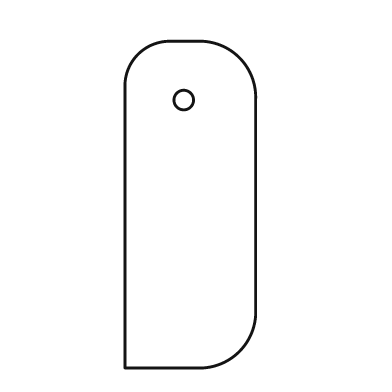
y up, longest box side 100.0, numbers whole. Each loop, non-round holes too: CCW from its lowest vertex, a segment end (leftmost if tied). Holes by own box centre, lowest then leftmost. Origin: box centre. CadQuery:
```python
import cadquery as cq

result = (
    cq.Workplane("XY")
    .moveTo(-20.0, -50.0)
    .lineTo(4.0, -50.0)
    .threePointArc((15.0, -45.0), (20.0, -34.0))
    .lineTo(20.0, 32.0)
    .threePointArc((15.0, 45.0), (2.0, 50.0))
    .lineTo(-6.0, 50.0)
    .threePointArc((-16.0, 46.0), (-20.0, 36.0))
    .close()
    .moveTo(-2.0, 32.0)
    .circle(3.0)
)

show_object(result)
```